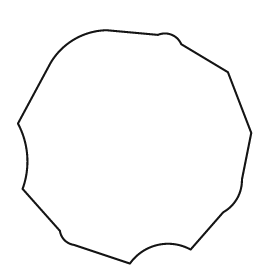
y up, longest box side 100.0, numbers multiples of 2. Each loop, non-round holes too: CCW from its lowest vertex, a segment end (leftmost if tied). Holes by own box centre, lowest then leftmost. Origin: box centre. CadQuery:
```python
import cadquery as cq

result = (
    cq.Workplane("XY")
    .moveTo(-2.0, -50.0)
    .threePointArc((10.0, -42.0), (24.0, -44.0))
    .lineTo(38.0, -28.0)
    .threePointArc((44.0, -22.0), (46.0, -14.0))
    .lineTo(50.0, 6.0)
    .lineTo(40.0, 32.0)
    .lineTo(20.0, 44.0)
    .threePointArc((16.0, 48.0), (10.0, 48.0))
    .lineTo(-12.0, 50.0)
    .threePointArc((-26.0, 46.0), (-36.0, 36.0))
    .lineTo(-50.0, 10.0)
    .threePointArc((-46.0, -4.0), (-48.0, -18.0))
    .lineTo(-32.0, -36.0)
    .threePointArc((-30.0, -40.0), (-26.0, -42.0))
    .close()
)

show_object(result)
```